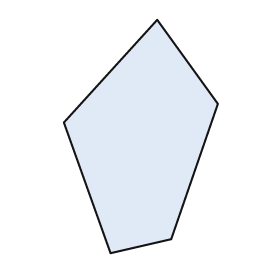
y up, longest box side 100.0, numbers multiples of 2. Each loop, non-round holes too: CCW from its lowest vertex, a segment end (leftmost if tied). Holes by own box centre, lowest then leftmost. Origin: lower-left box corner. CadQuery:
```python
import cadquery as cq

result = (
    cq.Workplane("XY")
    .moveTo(20.0, 0.0)
    .lineTo(46.0, 6.0)
    .lineTo(66.0, 64.0)
    .lineTo(40.0, 100.0)
    .lineTo(0.0, 56.0)
    .close()
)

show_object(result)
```